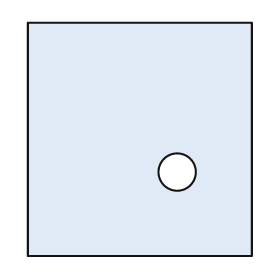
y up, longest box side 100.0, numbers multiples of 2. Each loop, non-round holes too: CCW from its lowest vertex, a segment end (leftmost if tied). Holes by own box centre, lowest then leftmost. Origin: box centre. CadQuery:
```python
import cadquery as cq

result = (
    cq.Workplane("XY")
    .moveTo(-48.0, -50.0)
    .lineTo(48.0, -50.0)
    .lineTo(48.0, 50.0)
    .lineTo(-48.0, 50.0)
    .close()
    .moveTo(16.0, -14.0)
    .circle(8.0)
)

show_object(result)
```